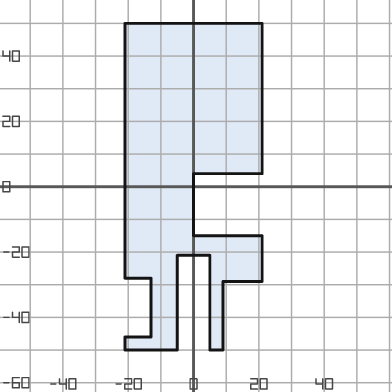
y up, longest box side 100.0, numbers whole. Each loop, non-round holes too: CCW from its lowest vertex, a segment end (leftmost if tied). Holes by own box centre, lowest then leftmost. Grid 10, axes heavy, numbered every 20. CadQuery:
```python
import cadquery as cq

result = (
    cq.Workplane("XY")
    .moveTo(-21.0, -50.0)
    .lineTo(-5.0, -50.0)
    .lineTo(-5.0, -21.0)
    .lineTo(5.0, -21.0)
    .lineTo(5.0, -50.0)
    .lineTo(9.0, -50.0)
    .lineTo(9.0, -29.0)
    .lineTo(21.0, -29.0)
    .lineTo(21.0, -15.0)
    .lineTo(0.0, -15.0)
    .lineTo(0.0, 4.0)
    .lineTo(21.0, 4.0)
    .lineTo(21.0, 50.0)
    .lineTo(-21.0, 50.0)
    .lineTo(-21.0, -28.0)
    .lineTo(-13.0, -28.0)
    .lineTo(-13.0, -46.0)
    .lineTo(-21.0, -46.0)
    .close()
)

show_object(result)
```